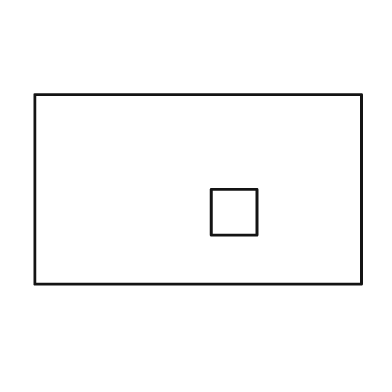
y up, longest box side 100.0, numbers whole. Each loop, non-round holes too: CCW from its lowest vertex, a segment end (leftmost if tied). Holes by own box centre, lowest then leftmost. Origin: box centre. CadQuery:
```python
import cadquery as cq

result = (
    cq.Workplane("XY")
    .moveTo(-50.0, -29.0)
    .lineTo(50.0, -29.0)
    .lineTo(50.0, 29.0)
    .lineTo(-50.0, 29.0)
    .close()
    .moveTo(4.0, -14.0)
    .lineTo(18.0, -14.0)
    .lineTo(18.0, 0.0)
    .lineTo(4.0, 0.0)
    .close()
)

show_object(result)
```